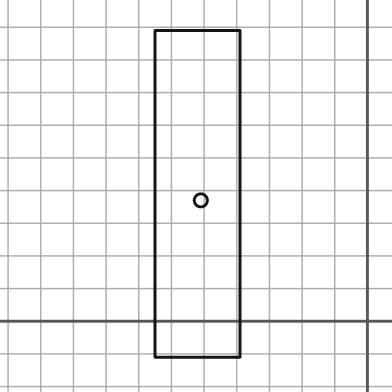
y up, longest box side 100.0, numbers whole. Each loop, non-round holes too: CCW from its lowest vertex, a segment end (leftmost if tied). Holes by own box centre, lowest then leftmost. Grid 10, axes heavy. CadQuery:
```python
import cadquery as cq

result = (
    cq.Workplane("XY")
    .moveTo(-65.0, -11.0)
    .lineTo(-39.0, -11.0)
    .lineTo(-39.0, 89.0)
    .lineTo(-65.0, 89.0)
    .close()
    .moveTo(-51.0, 37.0)
    .circle(2.0)
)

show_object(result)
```